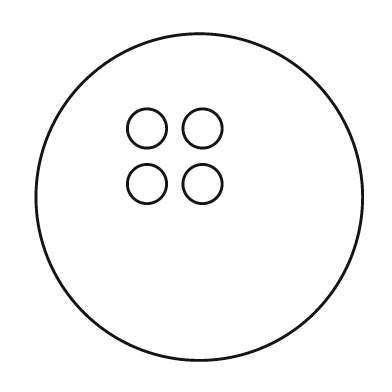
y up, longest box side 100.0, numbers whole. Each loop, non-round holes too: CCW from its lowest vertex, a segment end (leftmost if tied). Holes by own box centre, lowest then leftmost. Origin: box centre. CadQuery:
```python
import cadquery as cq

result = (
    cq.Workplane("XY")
    .moveTo(0.0, 0.0)
    .circle(50.0)
    .moveTo(-16.0, 4.0)
    .circle(6.0)
    .moveTo(1.0, 4.0)
    .circle(6.0)
    .moveTo(-16.0, 21.0)
    .circle(6.0)
    .moveTo(1.0, 21.0)
    .circle(6.0)
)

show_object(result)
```